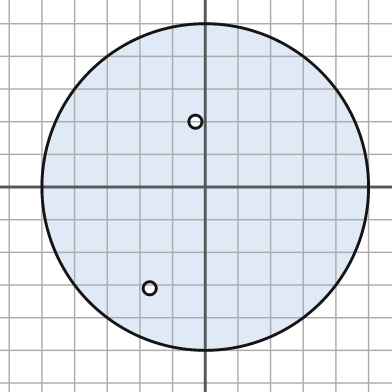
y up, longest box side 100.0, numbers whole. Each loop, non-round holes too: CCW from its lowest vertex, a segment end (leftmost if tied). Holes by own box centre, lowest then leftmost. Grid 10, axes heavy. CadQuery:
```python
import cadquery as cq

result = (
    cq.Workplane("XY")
    .moveTo(0.0, 0.0)
    .circle(50.0)
    .moveTo(-17.0, -31.0)
    .circle(2.0)
    .moveTo(-3.0, 20.0)
    .circle(2.0)
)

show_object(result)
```